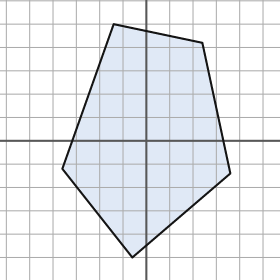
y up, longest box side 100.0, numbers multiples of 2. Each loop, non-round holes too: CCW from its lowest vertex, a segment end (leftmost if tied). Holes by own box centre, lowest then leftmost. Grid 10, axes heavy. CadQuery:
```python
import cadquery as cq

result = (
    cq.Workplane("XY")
    .moveTo(-6.0, -50.0)
    .lineTo(36.0, -14.0)
    .lineTo(24.0, 42.0)
    .lineTo(-14.0, 50.0)
    .lineTo(-36.0, -12.0)
    .close()
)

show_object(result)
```